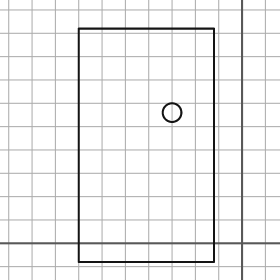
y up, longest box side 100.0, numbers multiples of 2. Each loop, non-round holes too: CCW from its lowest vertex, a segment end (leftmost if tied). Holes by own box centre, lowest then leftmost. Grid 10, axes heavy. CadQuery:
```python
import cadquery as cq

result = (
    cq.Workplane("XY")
    .moveTo(-70.0, -8.0)
    .lineTo(-12.0, -8.0)
    .lineTo(-12.0, 92.0)
    .lineTo(-70.0, 92.0)
    .close()
    .moveTo(-30.0, 56.0)
    .circle(4.0)
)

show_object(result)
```